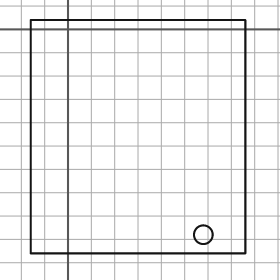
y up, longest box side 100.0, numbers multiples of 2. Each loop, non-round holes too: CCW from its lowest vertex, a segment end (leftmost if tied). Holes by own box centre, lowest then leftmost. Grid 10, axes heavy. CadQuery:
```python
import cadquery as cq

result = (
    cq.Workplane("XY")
    .moveTo(-16.0, -96.0)
    .lineTo(76.0, -96.0)
    .lineTo(76.0, 4.0)
    .lineTo(-16.0, 4.0)
    .close()
    .moveTo(58.0, -88.0)
    .circle(4.0)
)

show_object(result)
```